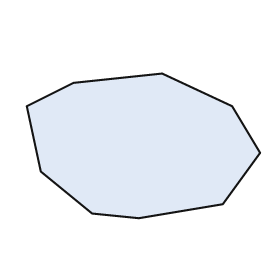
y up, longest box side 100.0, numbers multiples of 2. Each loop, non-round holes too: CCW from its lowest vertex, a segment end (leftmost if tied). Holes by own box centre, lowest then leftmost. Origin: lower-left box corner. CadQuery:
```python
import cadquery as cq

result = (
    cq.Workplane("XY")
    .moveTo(48.0, 0.0)
    .lineTo(84.0, 6.0)
    .lineTo(100.0, 28.0)
    .lineTo(88.0, 48.0)
    .lineTo(58.0, 62.0)
    .lineTo(20.0, 58.0)
    .lineTo(0.0, 48.0)
    .lineTo(6.0, 20.0)
    .lineTo(28.0, 2.0)
    .close()
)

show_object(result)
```